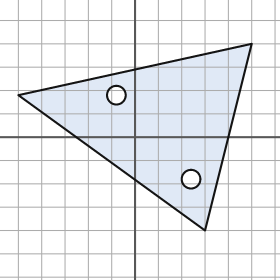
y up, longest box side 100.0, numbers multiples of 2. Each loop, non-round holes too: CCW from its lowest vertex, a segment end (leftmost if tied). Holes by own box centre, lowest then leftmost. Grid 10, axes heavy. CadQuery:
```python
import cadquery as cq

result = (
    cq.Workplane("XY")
    .moveTo(30.0, -40.0)
    .lineTo(50.0, 40.0)
    .lineTo(-50.0, 18.0)
    .close()
    .moveTo(24.0, -18.0)
    .circle(4.0)
    .moveTo(-8.0, 18.0)
    .circle(4.0)
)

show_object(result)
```